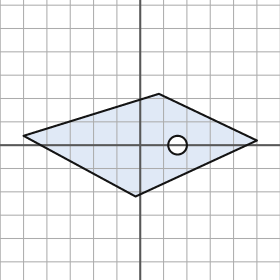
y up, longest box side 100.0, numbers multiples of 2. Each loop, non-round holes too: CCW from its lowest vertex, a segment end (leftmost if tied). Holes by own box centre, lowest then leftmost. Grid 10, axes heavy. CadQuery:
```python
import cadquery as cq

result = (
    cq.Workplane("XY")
    .moveTo(-2.0, -22.0)
    .lineTo(50.0, 2.0)
    .lineTo(8.0, 22.0)
    .lineTo(-50.0, 4.0)
    .close()
    .moveTo(16.0, 0.0)
    .circle(4.0)
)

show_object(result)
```